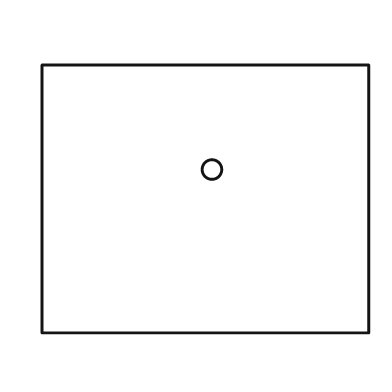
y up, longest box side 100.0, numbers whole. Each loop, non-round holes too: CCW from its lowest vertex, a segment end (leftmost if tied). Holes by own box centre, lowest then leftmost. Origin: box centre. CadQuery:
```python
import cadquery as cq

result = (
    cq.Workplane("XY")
    .moveTo(-50.0, -41.0)
    .lineTo(50.0, -41.0)
    .lineTo(50.0, 41.0)
    .lineTo(-50.0, 41.0)
    .close()
    .moveTo(2.0, 9.0)
    .circle(3.0)
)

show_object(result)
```